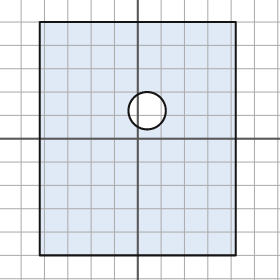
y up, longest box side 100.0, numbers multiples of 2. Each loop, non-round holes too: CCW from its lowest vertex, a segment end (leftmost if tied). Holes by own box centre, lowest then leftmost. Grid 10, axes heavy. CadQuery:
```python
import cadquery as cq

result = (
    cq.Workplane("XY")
    .moveTo(-42.0, -50.0)
    .lineTo(42.0, -50.0)
    .lineTo(42.0, 50.0)
    .lineTo(-42.0, 50.0)
    .close()
    .moveTo(4.0, 12.0)
    .circle(8.0)
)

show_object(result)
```